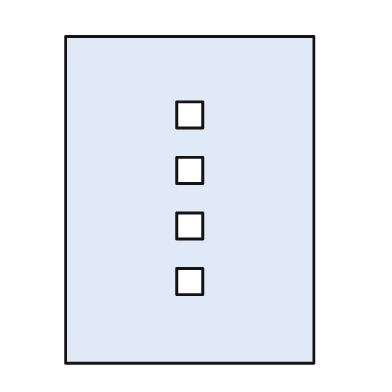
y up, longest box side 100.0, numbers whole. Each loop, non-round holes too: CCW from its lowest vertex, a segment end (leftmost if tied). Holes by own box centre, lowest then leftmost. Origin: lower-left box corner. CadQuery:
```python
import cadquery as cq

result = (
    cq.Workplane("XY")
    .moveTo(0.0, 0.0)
    .lineTo(76.0, 0.0)
    .lineTo(76.0, 100.0)
    .lineTo(0.0, 100.0)
    .close()
    .moveTo(34.0, 21.0)
    .lineTo(42.0, 21.0)
    .lineTo(42.0, 29.0)
    .lineTo(34.0, 29.0)
    .close()
    .moveTo(34.0, 38.0)
    .lineTo(42.0, 38.0)
    .lineTo(42.0, 46.0)
    .lineTo(34.0, 46.0)
    .close()
    .moveTo(34.0, 55.0)
    .lineTo(42.0, 55.0)
    .lineTo(42.0, 63.0)
    .lineTo(34.0, 63.0)
    .close()
    .moveTo(34.0, 72.0)
    .lineTo(42.0, 72.0)
    .lineTo(42.0, 80.0)
    .lineTo(34.0, 80.0)
    .close()
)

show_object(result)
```